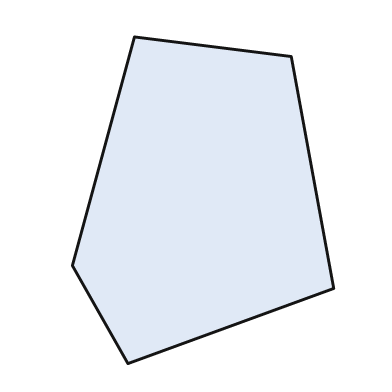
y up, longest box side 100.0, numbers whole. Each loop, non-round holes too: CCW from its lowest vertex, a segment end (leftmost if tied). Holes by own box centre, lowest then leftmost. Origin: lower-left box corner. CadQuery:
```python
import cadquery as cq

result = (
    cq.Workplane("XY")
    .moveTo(17.0, 0.0)
    .lineTo(80.0, 23.0)
    .lineTo(67.0, 94.0)
    .lineTo(19.0, 100.0)
    .lineTo(0.0, 30.0)
    .close()
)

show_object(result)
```